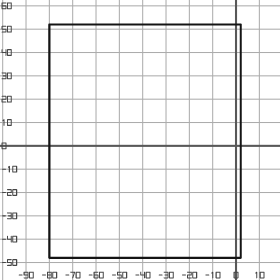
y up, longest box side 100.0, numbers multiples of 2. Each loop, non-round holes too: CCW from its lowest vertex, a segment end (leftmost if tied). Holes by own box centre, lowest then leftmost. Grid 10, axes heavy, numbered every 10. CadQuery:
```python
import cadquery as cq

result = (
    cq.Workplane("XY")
    .moveTo(-80.0, -48.0)
    .lineTo(2.0, -48.0)
    .lineTo(2.0, 52.0)
    .lineTo(-80.0, 52.0)
    .close()
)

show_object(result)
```